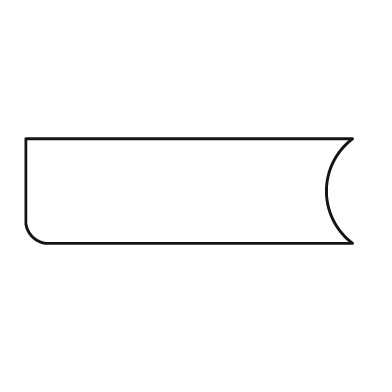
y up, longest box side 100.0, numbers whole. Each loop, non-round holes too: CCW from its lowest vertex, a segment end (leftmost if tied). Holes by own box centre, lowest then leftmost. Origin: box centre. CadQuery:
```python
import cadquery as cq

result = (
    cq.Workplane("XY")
    .moveTo(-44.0, -16.0)
    .lineTo(50.0, -16.0)
    .threePointArc((42.0, 0.0), (50.0, 16.0))
    .lineTo(-50.0, 16.0)
    .lineTo(-50.0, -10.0)
    .threePointArc((-48.0, -14.0), (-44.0, -16.0))
    .close()
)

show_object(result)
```